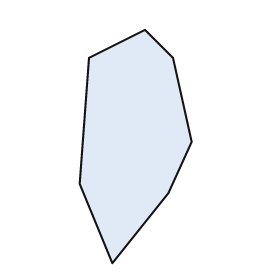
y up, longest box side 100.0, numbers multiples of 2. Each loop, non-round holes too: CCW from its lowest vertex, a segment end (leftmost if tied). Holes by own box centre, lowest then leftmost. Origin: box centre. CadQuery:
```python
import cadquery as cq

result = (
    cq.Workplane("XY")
    .moveTo(-10.0, -50.0)
    .lineTo(14.0, -20.0)
    .lineTo(24.0, 2.0)
    .lineTo(16.0, 38.0)
    .lineTo(4.0, 50.0)
    .lineTo(-20.0, 38.0)
    .lineTo(-24.0, -16.0)
    .close()
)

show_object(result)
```